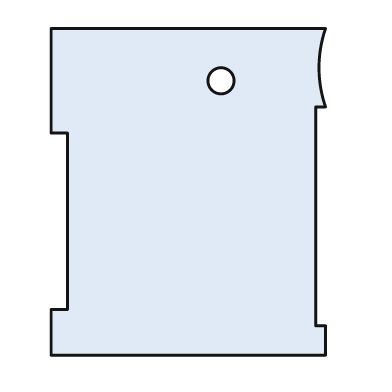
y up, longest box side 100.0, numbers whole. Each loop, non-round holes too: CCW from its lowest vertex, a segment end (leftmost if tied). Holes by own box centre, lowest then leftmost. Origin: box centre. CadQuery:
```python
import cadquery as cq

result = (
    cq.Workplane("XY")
    .moveTo(-42.0, -50.0)
    .lineTo(42.0, -50.0)
    .lineTo(42.0, -41.0)
    .lineTo(39.0, -41.0)
    .lineTo(39.0, 26.0)
    .lineTo(42.0, 26.0)
    .threePointArc((40.0, 38.0), (42.0, 50.0))
    .lineTo(-42.0, 50.0)
    .lineTo(-42.0, 18.0)
    .lineTo(-37.0, 18.0)
    .lineTo(-37.0, -36.0)
    .lineTo(-42.0, -36.0)
    .close()
    .moveTo(10.0, 34.0)
    .circle(4.0)
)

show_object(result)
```